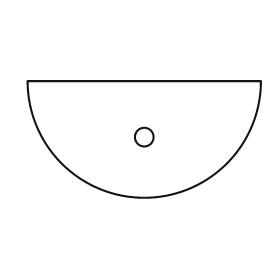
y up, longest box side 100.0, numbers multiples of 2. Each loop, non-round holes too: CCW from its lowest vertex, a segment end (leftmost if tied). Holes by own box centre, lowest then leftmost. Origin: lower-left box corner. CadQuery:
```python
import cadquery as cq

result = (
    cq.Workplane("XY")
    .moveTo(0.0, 50.0)
    .threePointArc((50.0, 0.0), (100.0, 50.0))
    .close()
    .moveTo(50.0, 26.0)
    .circle(4.0)
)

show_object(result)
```